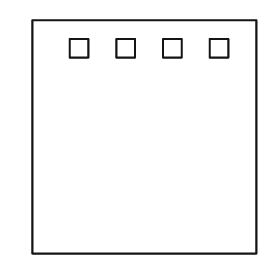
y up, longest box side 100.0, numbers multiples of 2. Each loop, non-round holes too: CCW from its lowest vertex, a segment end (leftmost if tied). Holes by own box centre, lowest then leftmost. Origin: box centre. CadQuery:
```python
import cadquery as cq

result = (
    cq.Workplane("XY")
    .moveTo(-48.0, -50.0)
    .lineTo(48.0, -50.0)
    .lineTo(48.0, 50.0)
    .lineTo(-48.0, 50.0)
    .close()
    .moveTo(-32.0, 34.0)
    .lineTo(-24.0, 34.0)
    .lineTo(-24.0, 42.0)
    .lineTo(-32.0, 42.0)
    .close()
    .moveTo(-12.0, 34.0)
    .lineTo(-4.0, 34.0)
    .lineTo(-4.0, 42.0)
    .lineTo(-12.0, 42.0)
    .close()
    .moveTo(8.0, 34.0)
    .lineTo(16.0, 34.0)
    .lineTo(16.0, 42.0)
    .lineTo(8.0, 42.0)
    .close()
    .moveTo(28.0, 34.0)
    .lineTo(36.0, 34.0)
    .lineTo(36.0, 42.0)
    .lineTo(28.0, 42.0)
    .close()
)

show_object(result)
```